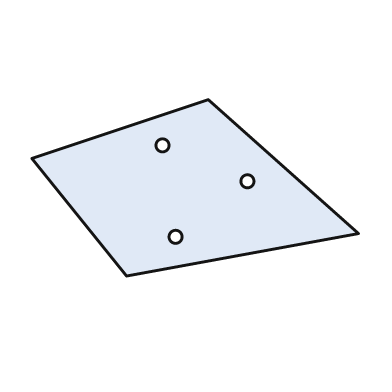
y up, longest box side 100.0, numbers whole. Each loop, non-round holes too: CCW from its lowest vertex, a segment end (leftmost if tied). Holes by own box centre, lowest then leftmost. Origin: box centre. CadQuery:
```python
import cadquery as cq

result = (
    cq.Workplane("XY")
    .moveTo(-21.0, -27.0)
    .lineTo(50.0, -14.0)
    .lineTo(4.0, 27.0)
    .lineTo(-50.0, 9.0)
    .close()
    .moveTo(-6.0, -15.0)
    .circle(2.0)
    .moveTo(16.0, 2.0)
    .circle(2.0)
    .moveTo(-10.0, 13.0)
    .circle(2.0)
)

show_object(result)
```